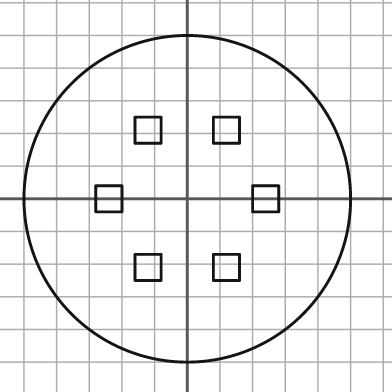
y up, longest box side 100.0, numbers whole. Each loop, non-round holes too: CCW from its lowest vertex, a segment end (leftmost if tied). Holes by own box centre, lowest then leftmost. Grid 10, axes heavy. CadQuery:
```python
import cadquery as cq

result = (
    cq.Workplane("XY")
    .moveTo(0.0, 0.0)
    .circle(50.0)
    .moveTo(-16.0, -25.0)
    .lineTo(-8.0, -25.0)
    .lineTo(-8.0, -17.0)
    .lineTo(-16.0, -17.0)
    .close()
    .moveTo(8.0, -25.0)
    .lineTo(16.0, -25.0)
    .lineTo(16.0, -17.0)
    .lineTo(8.0, -17.0)
    .close()
    .moveTo(-28.0, -4.0)
    .lineTo(-20.0, -4.0)
    .lineTo(-20.0, 4.0)
    .lineTo(-28.0, 4.0)
    .close()
    .moveTo(20.0, -4.0)
    .lineTo(28.0, -4.0)
    .lineTo(28.0, 4.0)
    .lineTo(20.0, 4.0)
    .close()
    .moveTo(-16.0, 17.0)
    .lineTo(-8.0, 17.0)
    .lineTo(-8.0, 25.0)
    .lineTo(-16.0, 25.0)
    .close()
    .moveTo(8.0, 17.0)
    .lineTo(16.0, 17.0)
    .lineTo(16.0, 25.0)
    .lineTo(8.0, 25.0)
    .close()
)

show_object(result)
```